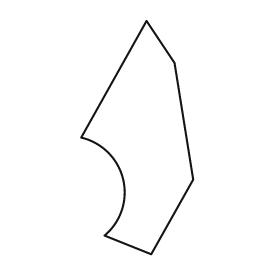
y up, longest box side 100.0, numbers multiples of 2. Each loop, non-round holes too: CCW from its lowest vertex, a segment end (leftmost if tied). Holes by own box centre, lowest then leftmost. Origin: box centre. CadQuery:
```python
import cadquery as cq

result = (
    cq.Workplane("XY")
    .moveTo(6.0, -50.0)
    .lineTo(24.0, -18.0)
    .lineTo(16.0, 32.0)
    .lineTo(4.0, 50.0)
    .lineTo(-24.0, 0.0)
    .threePointArc((-6.0, -18.0), (-14.0, -42.0))
    .close()
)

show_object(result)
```